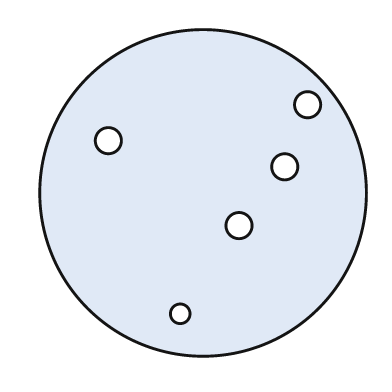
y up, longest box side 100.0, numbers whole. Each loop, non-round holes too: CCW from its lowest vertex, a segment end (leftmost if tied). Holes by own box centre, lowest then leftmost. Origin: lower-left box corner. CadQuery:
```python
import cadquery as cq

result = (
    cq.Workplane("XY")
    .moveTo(50.0, 50.0)
    .circle(50.0)
    .moveTo(43.0, 13.0)
    .circle(3.0)
    .moveTo(61.0, 40.0)
    .circle(4.0)
    .moveTo(75.0, 58.0)
    .circle(4.0)
    .moveTo(21.0, 66.0)
    .circle(4.0)
    .moveTo(82.0, 77.0)
    .circle(4.0)
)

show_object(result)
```